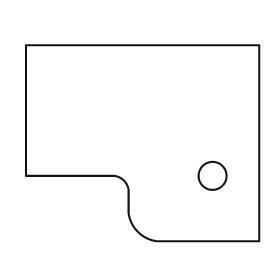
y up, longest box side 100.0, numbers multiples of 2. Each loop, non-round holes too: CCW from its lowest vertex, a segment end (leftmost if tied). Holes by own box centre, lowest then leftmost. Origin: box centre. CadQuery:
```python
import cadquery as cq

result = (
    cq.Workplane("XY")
    .moveTo(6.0, -42.0)
    .lineTo(50.0, -42.0)
    .lineTo(50.0, 42.0)
    .lineTo(-50.0, 42.0)
    .lineTo(-50.0, -14.0)
    .lineTo(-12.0, -14.0)
    .threePointArc((-8.0, -16.0), (-6.0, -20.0))
    .lineTo(-6.0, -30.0)
    .threePointArc((-2.0, -38.0), (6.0, -42.0))
    .close()
    .moveTo(30.0, -14.0)
    .circle(6.0)
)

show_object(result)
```